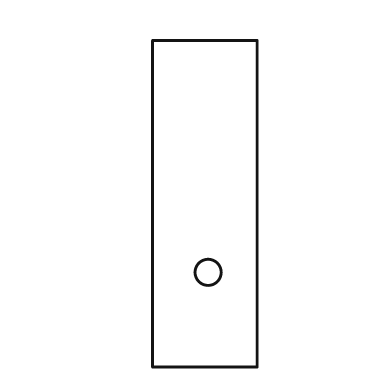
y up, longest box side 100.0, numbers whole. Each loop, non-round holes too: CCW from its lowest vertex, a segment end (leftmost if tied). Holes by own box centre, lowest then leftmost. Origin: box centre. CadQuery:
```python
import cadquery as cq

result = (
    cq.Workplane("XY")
    .moveTo(-16.0, -50.0)
    .lineTo(16.0, -50.0)
    .lineTo(16.0, 50.0)
    .lineTo(-16.0, 50.0)
    .close()
    .moveTo(1.0, -21.0)
    .circle(4.0)
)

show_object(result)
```